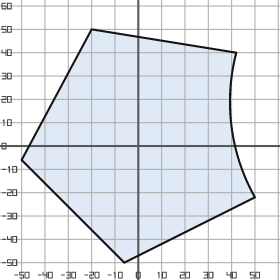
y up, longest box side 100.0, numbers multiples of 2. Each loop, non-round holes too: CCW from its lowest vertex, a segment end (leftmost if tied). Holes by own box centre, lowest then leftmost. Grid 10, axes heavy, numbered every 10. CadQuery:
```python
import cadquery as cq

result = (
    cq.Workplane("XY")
    .moveTo(-6.0, -50.0)
    .lineTo(50.0, -22.0)
    .threePointArc((40.0, 8.0), (42.0, 40.0))
    .lineTo(-20.0, 50.0)
    .lineTo(-50.0, -6.0)
    .close()
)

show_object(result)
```